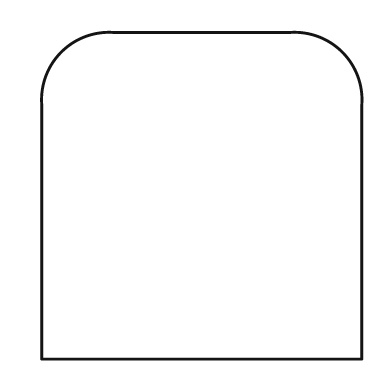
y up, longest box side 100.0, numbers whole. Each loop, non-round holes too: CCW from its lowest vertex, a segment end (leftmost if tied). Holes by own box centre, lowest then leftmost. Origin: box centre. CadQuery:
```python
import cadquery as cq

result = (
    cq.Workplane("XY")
    .moveTo(-49.0, -50.0)
    .lineTo(49.0, -50.0)
    .lineTo(49.0, 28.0)
    .threePointArc((43.0, 44.0), (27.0, 50.0))
    .lineTo(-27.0, 50.0)
    .threePointArc((-43.0, 44.0), (-49.0, 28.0))
    .close()
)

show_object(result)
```